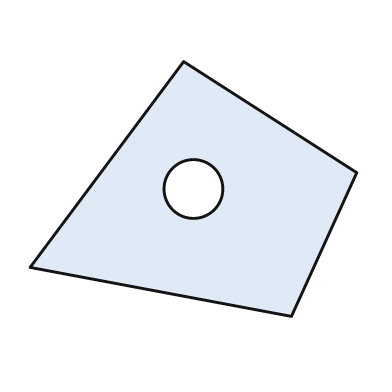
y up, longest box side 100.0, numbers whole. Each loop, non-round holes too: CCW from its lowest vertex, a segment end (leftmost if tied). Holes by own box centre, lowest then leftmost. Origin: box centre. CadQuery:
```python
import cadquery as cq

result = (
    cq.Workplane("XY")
    .moveTo(30.0, -39.0)
    .lineTo(50.0, 5.0)
    .lineTo(-3.0, 39.0)
    .lineTo(-50.0, -24.0)
    .close()
    .moveTo(0.0, 0.0)
    .circle(9.0)
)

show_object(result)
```